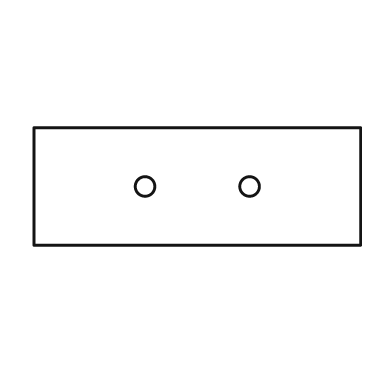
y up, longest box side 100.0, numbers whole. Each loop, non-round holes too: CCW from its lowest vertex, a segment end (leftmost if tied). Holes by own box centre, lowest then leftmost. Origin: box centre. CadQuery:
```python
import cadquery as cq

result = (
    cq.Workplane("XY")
    .moveTo(-50.0, -18.0)
    .lineTo(50.0, -18.0)
    .lineTo(50.0, 18.0)
    .lineTo(-50.0, 18.0)
    .close()
    .moveTo(-16.0, 0.0)
    .circle(3.0)
    .moveTo(16.0, 0.0)
    .circle(3.0)
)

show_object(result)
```